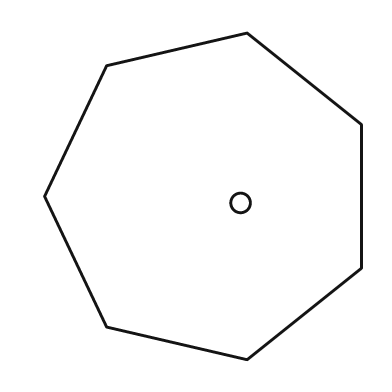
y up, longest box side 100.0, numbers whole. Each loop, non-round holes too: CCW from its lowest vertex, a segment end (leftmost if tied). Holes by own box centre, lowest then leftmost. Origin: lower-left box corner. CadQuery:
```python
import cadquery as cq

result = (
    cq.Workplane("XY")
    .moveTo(62.0, 0.0)
    .lineTo(97.0, 28.0)
    .lineTo(97.0, 72.0)
    .lineTo(62.0, 100.0)
    .lineTo(19.0, 90.0)
    .lineTo(0.0, 50.0)
    .lineTo(19.0, 10.0)
    .close()
    .moveTo(60.0, 48.0)
    .circle(3.0)
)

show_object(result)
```